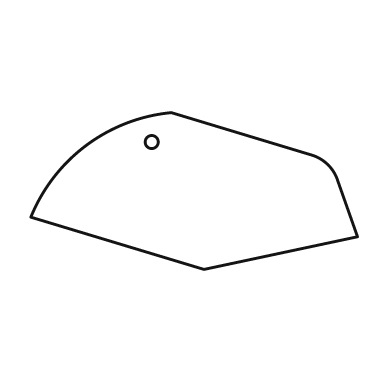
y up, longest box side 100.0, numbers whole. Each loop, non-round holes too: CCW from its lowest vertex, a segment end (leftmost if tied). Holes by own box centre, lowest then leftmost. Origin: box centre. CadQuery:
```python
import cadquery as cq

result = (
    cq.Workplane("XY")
    .moveTo(3.0, -24.0)
    .lineTo(50.0, -14.0)
    .lineTo(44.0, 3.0)
    .threePointArc((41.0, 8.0), (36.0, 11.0))
    .lineTo(-7.0, 24.0)
    .threePointArc((-33.0, 14.0), (-50.0, -8.0))
    .close()
    .moveTo(-13.0, 15.0)
    .circle(2.0)
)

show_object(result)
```